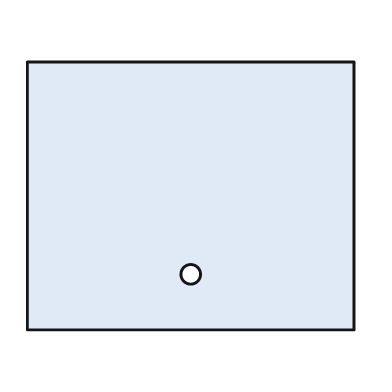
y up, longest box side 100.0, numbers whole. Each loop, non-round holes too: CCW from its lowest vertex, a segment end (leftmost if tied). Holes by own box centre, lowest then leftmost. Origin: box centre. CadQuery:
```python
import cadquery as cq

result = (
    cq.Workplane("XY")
    .moveTo(-50.0, -41.0)
    .lineTo(50.0, -41.0)
    .lineTo(50.0, 41.0)
    .lineTo(-50.0, 41.0)
    .close()
    .moveTo(0.0, -24.0)
    .circle(3.0)
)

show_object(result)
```